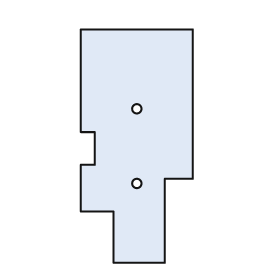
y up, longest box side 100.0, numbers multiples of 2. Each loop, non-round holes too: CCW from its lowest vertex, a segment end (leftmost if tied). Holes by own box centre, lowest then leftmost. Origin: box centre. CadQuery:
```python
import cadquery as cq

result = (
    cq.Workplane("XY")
    .moveTo(-10.0, -50.0)
    .lineTo(12.0, -50.0)
    .lineTo(12.0, -14.0)
    .lineTo(24.0, -14.0)
    .lineTo(24.0, 50.0)
    .lineTo(-24.0, 50.0)
    .lineTo(-24.0, 6.0)
    .lineTo(-18.0, 6.0)
    .lineTo(-18.0, -8.0)
    .lineTo(-24.0, -8.0)
    .lineTo(-24.0, -28.0)
    .lineTo(-10.0, -28.0)
    .close()
    .moveTo(0.0, -16.0)
    .circle(2.0)
    .moveTo(0.0, 16.0)
    .circle(2.0)
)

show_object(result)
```